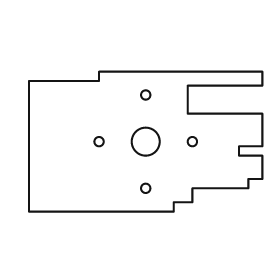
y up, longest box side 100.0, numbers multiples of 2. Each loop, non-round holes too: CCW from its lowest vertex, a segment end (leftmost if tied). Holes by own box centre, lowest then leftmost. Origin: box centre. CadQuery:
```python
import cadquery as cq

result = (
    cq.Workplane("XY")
    .moveTo(-50.0, -30.0)
    .lineTo(12.0, -30.0)
    .lineTo(12.0, -26.0)
    .lineTo(20.0, -26.0)
    .lineTo(20.0, -20.0)
    .lineTo(44.0, -20.0)
    .lineTo(44.0, -16.0)
    .lineTo(50.0, -16.0)
    .lineTo(50.0, -6.0)
    .lineTo(40.0, -6.0)
    .lineTo(40.0, -2.0)
    .lineTo(50.0, -2.0)
    .lineTo(50.0, 12.0)
    .lineTo(18.0, 12.0)
    .lineTo(18.0, 24.0)
    .lineTo(50.0, 24.0)
    .lineTo(50.0, 30.0)
    .lineTo(-20.0, 30.0)
    .lineTo(-20.0, 26.0)
    .lineTo(-50.0, 26.0)
    .close()
    .moveTo(0.0, -20.0)
    .circle(2.0)
    .moveTo(-20.0, 0.0)
    .circle(2.0)
    .moveTo(0.0, 0.0)
    .circle(6.0)
    .moveTo(20.0, 0.0)
    .circle(2.0)
    .moveTo(0.0, 20.0)
    .circle(2.0)
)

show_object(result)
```